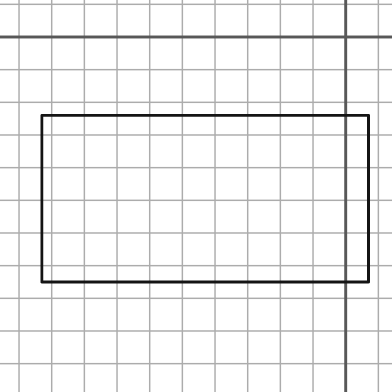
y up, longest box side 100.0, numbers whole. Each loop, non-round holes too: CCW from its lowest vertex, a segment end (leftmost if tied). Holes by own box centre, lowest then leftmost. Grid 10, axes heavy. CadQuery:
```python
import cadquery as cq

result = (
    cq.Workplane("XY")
    .moveTo(-93.0, -75.0)
    .lineTo(7.0, -75.0)
    .lineTo(7.0, -24.0)
    .lineTo(-93.0, -24.0)
    .close()
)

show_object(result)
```